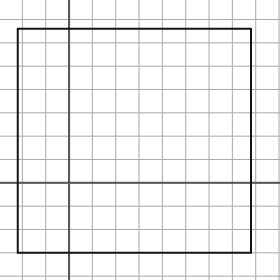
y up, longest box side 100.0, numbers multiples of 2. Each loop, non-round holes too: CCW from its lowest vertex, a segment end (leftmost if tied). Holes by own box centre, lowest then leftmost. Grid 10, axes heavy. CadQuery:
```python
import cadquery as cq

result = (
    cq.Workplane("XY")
    .moveTo(-22.0, -30.0)
    .lineTo(78.0, -30.0)
    .lineTo(78.0, 66.0)
    .lineTo(-22.0, 66.0)
    .close()
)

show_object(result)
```